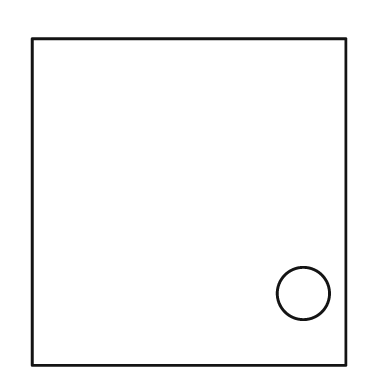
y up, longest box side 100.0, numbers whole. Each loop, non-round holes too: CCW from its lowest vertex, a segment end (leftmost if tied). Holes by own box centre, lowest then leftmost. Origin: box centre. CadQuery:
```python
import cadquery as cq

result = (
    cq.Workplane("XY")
    .moveTo(-48.0, -50.0)
    .lineTo(48.0, -50.0)
    .lineTo(48.0, 50.0)
    .lineTo(-48.0, 50.0)
    .close()
    .moveTo(35.0, -28.0)
    .circle(8.0)
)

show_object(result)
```